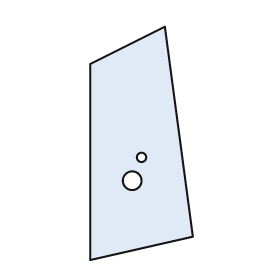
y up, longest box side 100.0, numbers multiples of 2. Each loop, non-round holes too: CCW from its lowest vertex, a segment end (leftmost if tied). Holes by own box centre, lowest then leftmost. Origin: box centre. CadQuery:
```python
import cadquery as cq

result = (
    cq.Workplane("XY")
    .moveTo(-22.0, -50.0)
    .lineTo(22.0, -40.0)
    .lineTo(10.0, 50.0)
    .lineTo(-22.0, 34.0)
    .close()
    .moveTo(-4.0, -16.0)
    .circle(4.0)
    .moveTo(0.0, -6.0)
    .circle(2.0)
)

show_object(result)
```